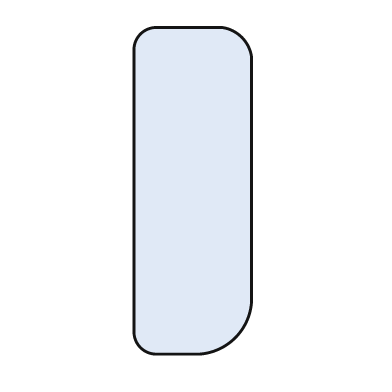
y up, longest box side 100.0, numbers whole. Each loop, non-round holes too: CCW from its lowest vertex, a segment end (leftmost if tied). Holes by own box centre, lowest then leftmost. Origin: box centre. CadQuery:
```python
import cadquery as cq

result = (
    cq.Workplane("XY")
    .moveTo(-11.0, -50.0)
    .lineTo(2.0, -50.0)
    .threePointArc((13.0, -45.0), (18.0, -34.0))
    .lineTo(18.0, 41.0)
    .threePointArc((15.0, 47.0), (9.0, 50.0))
    .lineTo(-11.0, 50.0)
    .threePointArc((-16.0, 48.0), (-18.0, 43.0))
    .lineTo(-18.0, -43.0)
    .threePointArc((-16.0, -48.0), (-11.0, -50.0))
    .close()
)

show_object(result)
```